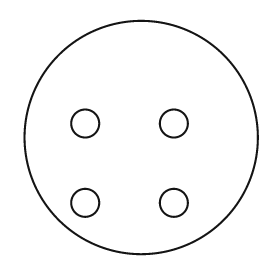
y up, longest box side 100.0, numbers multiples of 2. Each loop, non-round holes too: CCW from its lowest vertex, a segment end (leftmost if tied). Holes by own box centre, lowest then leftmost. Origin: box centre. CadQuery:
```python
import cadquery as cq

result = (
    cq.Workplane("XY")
    .moveTo(0.0, 0.0)
    .circle(50.0)
    .moveTo(-24.0, -28.0)
    .circle(6.0)
    .moveTo(14.0, -28.0)
    .circle(6.0)
    .moveTo(-24.0, 6.0)
    .circle(6.0)
    .moveTo(14.0, 6.0)
    .circle(6.0)
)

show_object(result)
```